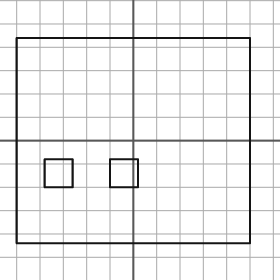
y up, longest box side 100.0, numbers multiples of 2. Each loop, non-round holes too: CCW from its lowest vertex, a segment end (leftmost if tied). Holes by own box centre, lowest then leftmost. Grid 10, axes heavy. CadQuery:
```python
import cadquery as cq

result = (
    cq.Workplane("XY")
    .moveTo(-50.0, -44.0)
    .lineTo(50.0, -44.0)
    .lineTo(50.0, 44.0)
    .lineTo(-50.0, 44.0)
    .close()
    .moveTo(-38.0, -20.0)
    .lineTo(-26.0, -20.0)
    .lineTo(-26.0, -8.0)
    .lineTo(-38.0, -8.0)
    .close()
    .moveTo(-10.0, -20.0)
    .lineTo(2.0, -20.0)
    .lineTo(2.0, -8.0)
    .lineTo(-10.0, -8.0)
    .close()
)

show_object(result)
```